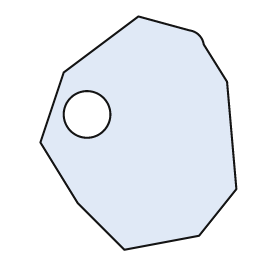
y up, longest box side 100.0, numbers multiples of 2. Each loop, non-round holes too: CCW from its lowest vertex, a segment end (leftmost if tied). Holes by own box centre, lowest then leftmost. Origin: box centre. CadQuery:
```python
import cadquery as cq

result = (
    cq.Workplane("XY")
    .moveTo(-6.0, -50.0)
    .lineTo(26.0, -44.0)
    .lineTo(42.0, -24.0)
    .lineTo(38.0, 22.0)
    .lineTo(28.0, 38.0)
    .threePointArc((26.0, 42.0), (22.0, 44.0))
    .lineTo(0.0, 50.0)
    .lineTo(-32.0, 26.0)
    .lineTo(-42.0, -4.0)
    .lineTo(-26.0, -30.0)
    .close()
    .moveTo(-22.0, 8.0)
    .circle(10.0)
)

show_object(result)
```